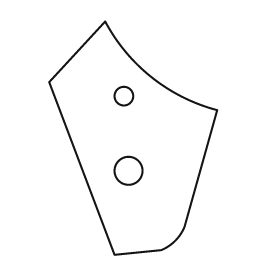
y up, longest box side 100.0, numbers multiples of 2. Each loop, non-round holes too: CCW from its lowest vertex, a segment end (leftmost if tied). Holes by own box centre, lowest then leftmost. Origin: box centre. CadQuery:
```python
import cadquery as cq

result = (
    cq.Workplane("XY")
    .moveTo(-8.0, -50.0)
    .lineTo(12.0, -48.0)
    .threePointArc((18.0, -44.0), (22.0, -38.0))
    .lineTo(36.0, 12.0)
    .threePointArc((8.0, 26.0), (-12.0, 50.0))
    .lineTo(-36.0, 24.0)
    .close()
    .moveTo(-2.0, -14.0)
    .circle(6.0)
    .moveTo(-4.0, 18.0)
    .circle(4.0)
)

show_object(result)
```